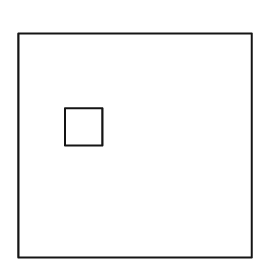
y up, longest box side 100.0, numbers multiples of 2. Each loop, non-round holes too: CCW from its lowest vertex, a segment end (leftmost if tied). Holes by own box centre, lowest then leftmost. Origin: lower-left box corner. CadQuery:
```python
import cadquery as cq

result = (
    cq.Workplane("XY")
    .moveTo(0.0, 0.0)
    .lineTo(100.0, 0.0)
    .lineTo(100.0, 96.0)
    .lineTo(0.0, 96.0)
    .close()
    .moveTo(20.0, 48.0)
    .lineTo(36.0, 48.0)
    .lineTo(36.0, 64.0)
    .lineTo(20.0, 64.0)
    .close()
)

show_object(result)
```